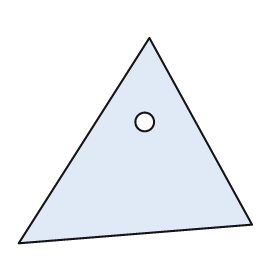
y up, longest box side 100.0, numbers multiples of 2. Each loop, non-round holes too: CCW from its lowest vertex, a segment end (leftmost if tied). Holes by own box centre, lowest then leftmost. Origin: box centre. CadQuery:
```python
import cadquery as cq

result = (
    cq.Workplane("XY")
    .moveTo(-50.0, -44.0)
    .lineTo(50.0, -36.0)
    .lineTo(6.0, 44.0)
    .close()
    .moveTo(4.0, 8.0)
    .circle(4.0)
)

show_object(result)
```